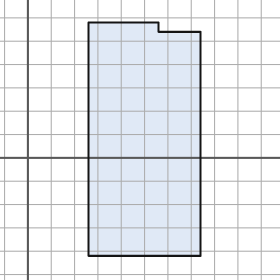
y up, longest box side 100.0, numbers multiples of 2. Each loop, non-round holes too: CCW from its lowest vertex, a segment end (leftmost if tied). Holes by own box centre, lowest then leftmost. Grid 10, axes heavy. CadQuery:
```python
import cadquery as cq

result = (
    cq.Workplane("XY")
    .moveTo(26.0, -42.0)
    .lineTo(74.0, -42.0)
    .lineTo(74.0, 54.0)
    .lineTo(56.0, 54.0)
    .lineTo(56.0, 58.0)
    .lineTo(26.0, 58.0)
    .close()
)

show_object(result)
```